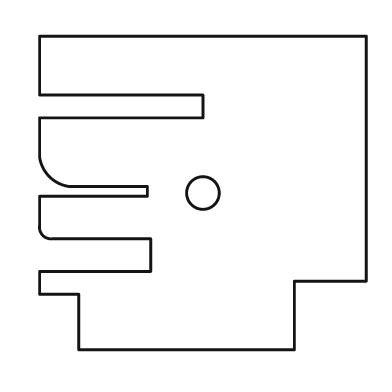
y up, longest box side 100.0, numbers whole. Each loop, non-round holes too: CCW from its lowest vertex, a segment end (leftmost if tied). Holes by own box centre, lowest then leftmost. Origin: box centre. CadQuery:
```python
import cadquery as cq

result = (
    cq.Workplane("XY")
    .moveTo(-38.0, -48.0)
    .lineTo(28.0, -48.0)
    .lineTo(28.0, -27.0)
    .lineTo(50.0, -27.0)
    .lineTo(50.0, 48.0)
    .lineTo(-50.0, 48.0)
    .lineTo(-50.0, 30.0)
    .lineTo(0.0, 30.0)
    .lineTo(0.0, 23.0)
    .lineTo(-50.0, 23.0)
    .lineTo(-50.0, 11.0)
    .threePointArc((-47.0, 5.0), (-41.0, 2.0))
    .lineTo(-17.0, 2.0)
    .lineTo(-17.0, -1.0)
    .lineTo(-50.0, -1.0)
    .lineTo(-50.0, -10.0)
    .threePointArc((-49.0, -13.0), (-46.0, -14.0))
    .lineTo(-16.0, -14.0)
    .lineTo(-16.0, -24.0)
    .lineTo(-50.0, -24.0)
    .lineTo(-50.0, -31.0)
    .lineTo(-38.0, -31.0)
    .close()
    .moveTo(0.0, 0.0)
    .circle(5.0)
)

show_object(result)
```